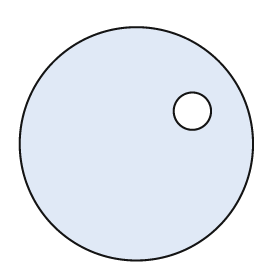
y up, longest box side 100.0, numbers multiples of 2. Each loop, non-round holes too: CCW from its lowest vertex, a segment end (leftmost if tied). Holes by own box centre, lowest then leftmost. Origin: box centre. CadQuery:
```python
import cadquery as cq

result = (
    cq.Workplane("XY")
    .moveTo(0.0, 0.0)
    .circle(50.0)
    .moveTo(24.0, 14.0)
    .circle(8.0)
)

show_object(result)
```